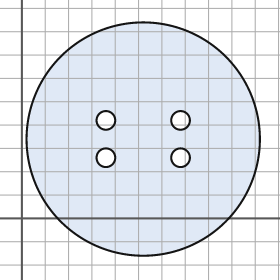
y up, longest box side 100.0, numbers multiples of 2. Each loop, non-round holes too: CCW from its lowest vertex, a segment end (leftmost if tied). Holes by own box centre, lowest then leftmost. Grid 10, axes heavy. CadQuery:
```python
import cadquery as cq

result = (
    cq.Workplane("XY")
    .moveTo(52.0, 34.0)
    .circle(50.0)
    .moveTo(36.0, 26.0)
    .circle(4.0)
    .moveTo(68.0, 26.0)
    .circle(4.0)
    .moveTo(36.0, 42.0)
    .circle(4.0)
    .moveTo(68.0, 42.0)
    .circle(4.0)
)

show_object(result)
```